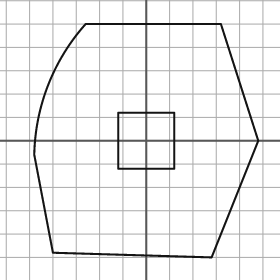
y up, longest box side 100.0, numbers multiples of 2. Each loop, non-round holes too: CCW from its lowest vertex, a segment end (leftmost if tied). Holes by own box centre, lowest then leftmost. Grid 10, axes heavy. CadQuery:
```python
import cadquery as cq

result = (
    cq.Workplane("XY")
    .moveTo(28.0, -50.0)
    .lineTo(48.0, 0.0)
    .lineTo(32.0, 50.0)
    .lineTo(-26.0, 50.0)
    .threePointArc((-42.0, 24.0), (-48.0, -6.0))
    .lineTo(-40.0, -48.0)
    .close()
    .moveTo(-12.0, -12.0)
    .lineTo(12.0, -12.0)
    .lineTo(12.0, 12.0)
    .lineTo(-12.0, 12.0)
    .close()
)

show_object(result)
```